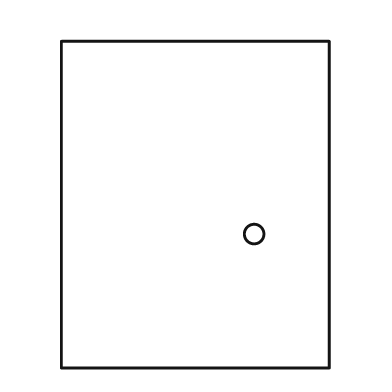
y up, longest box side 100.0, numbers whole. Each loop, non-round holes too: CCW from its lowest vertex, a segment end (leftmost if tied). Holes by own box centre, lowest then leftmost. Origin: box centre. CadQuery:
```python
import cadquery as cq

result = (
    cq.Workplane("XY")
    .moveTo(-41.0, -50.0)
    .lineTo(41.0, -50.0)
    .lineTo(41.0, 50.0)
    .lineTo(-41.0, 50.0)
    .close()
    .moveTo(18.0, -9.0)
    .circle(3.0)
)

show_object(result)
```